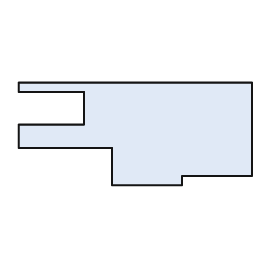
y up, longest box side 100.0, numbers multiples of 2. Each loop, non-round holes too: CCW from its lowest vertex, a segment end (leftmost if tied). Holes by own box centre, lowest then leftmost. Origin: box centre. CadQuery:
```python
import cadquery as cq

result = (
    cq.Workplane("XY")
    .moveTo(-10.0, -22.0)
    .lineTo(20.0, -22.0)
    .lineTo(20.0, -18.0)
    .lineTo(50.0, -18.0)
    .lineTo(50.0, 22.0)
    .lineTo(-50.0, 22.0)
    .lineTo(-50.0, 18.0)
    .lineTo(-22.0, 18.0)
    .lineTo(-22.0, 4.0)
    .lineTo(-50.0, 4.0)
    .lineTo(-50.0, -6.0)
    .lineTo(-10.0, -6.0)
    .close()
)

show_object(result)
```